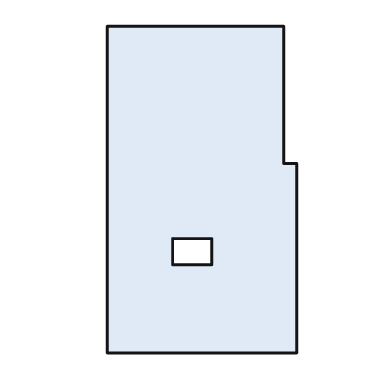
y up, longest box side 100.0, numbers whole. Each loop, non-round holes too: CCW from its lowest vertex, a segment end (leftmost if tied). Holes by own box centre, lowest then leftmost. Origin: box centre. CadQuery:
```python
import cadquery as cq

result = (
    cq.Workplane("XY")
    .moveTo(-29.0, -50.0)
    .lineTo(29.0, -50.0)
    .lineTo(29.0, 8.0)
    .lineTo(25.0, 8.0)
    .lineTo(25.0, 50.0)
    .lineTo(-29.0, 50.0)
    .close()
    .moveTo(-9.0, -23.0)
    .lineTo(3.0, -23.0)
    .lineTo(3.0, -15.0)
    .lineTo(-9.0, -15.0)
    .close()
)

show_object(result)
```